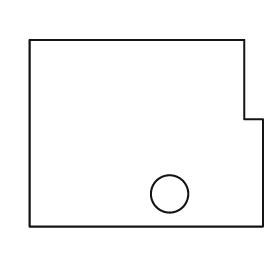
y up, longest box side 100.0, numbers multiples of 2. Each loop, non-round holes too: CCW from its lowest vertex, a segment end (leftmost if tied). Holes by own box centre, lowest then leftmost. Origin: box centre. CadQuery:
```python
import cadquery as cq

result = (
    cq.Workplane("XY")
    .moveTo(-50.0, -40.0)
    .lineTo(50.0, -40.0)
    .lineTo(50.0, 6.0)
    .lineTo(42.0, 6.0)
    .lineTo(42.0, 40.0)
    .lineTo(-50.0, 40.0)
    .close()
    .moveTo(10.0, -26.0)
    .circle(8.0)
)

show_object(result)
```